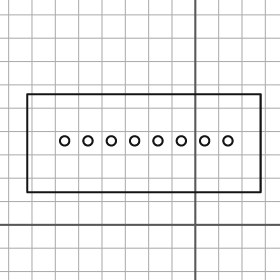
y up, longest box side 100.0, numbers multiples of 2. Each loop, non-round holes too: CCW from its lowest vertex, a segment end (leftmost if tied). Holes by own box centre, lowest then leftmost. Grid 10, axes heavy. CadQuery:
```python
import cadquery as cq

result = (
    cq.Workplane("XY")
    .moveTo(-72.0, 14.0)
    .lineTo(28.0, 14.0)
    .lineTo(28.0, 56.0)
    .lineTo(-72.0, 56.0)
    .close()
    .moveTo(-56.0, 36.0)
    .circle(2.0)
    .moveTo(-46.0, 36.0)
    .circle(2.0)
    .moveTo(-36.0, 36.0)
    .circle(2.0)
    .moveTo(-26.0, 36.0)
    .circle(2.0)
    .moveTo(-16.0, 36.0)
    .circle(2.0)
    .moveTo(-6.0, 36.0)
    .circle(2.0)
    .moveTo(4.0, 36.0)
    .circle(2.0)
    .moveTo(14.0, 36.0)
    .circle(2.0)
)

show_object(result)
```